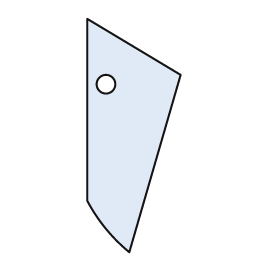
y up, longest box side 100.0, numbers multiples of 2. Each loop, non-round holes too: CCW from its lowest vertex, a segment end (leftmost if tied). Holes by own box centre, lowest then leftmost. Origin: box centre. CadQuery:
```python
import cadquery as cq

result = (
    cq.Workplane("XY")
    .moveTo(-2.0, -50.0)
    .lineTo(20.0, 26.0)
    .lineTo(-20.0, 50.0)
    .lineTo(-20.0, -28.0)
    .threePointArc((-12.0, -40.0), (-2.0, -50.0))
    .close()
    .moveTo(-12.0, 22.0)
    .circle(4.0)
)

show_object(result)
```